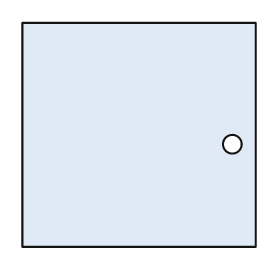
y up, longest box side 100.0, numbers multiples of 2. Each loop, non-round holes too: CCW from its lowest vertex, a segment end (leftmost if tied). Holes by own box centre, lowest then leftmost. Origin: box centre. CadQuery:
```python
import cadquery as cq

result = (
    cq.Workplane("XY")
    .moveTo(-50.0, -48.0)
    .lineTo(50.0, -48.0)
    .lineTo(50.0, 48.0)
    .lineTo(-50.0, 48.0)
    .close()
    .moveTo(40.0, -4.0)
    .circle(4.0)
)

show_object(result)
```